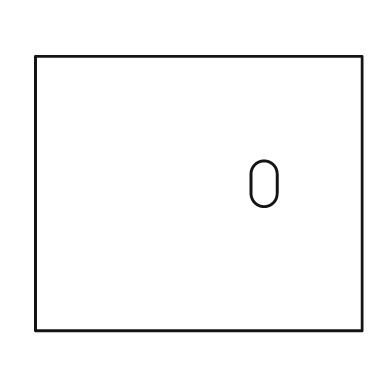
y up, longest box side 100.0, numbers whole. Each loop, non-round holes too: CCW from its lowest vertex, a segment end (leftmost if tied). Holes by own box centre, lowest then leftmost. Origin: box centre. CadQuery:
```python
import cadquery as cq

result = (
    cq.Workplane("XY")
    .moveTo(-50.0, -42.0)
    .lineTo(50.0, -42.0)
    .lineTo(50.0, 42.0)
    .lineTo(-50.0, 42.0)
    .close()
    .moveTo(16.0, 0.0)
    .threePointArc((20.0, -4.0), (24.0, 0.0))
    .lineTo(24.0, 6.0)
    .threePointArc((20.0, 10.0), (16.0, 6.0))
    .close()
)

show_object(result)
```